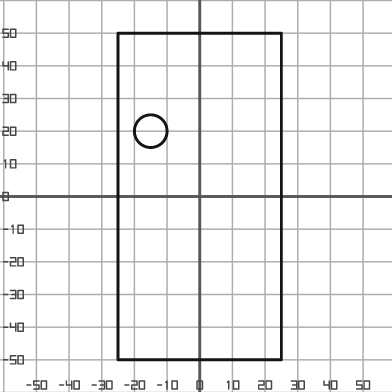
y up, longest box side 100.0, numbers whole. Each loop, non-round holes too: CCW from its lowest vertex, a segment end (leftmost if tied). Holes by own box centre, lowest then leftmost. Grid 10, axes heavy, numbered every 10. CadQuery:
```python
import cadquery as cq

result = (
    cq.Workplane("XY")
    .moveTo(-25.0, -50.0)
    .lineTo(25.0, -50.0)
    .lineTo(25.0, 50.0)
    .lineTo(-25.0, 50.0)
    .close()
    .moveTo(-15.0, 20.0)
    .circle(5.0)
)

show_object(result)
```